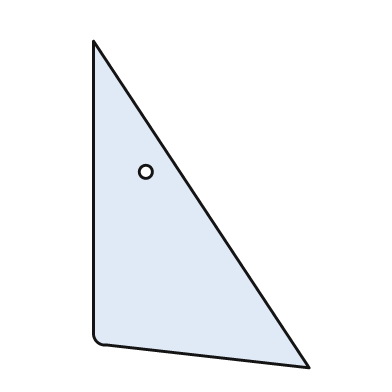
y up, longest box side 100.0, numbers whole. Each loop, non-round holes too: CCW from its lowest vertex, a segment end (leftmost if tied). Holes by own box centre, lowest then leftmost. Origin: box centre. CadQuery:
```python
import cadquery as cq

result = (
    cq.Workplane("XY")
    .moveTo(33.0, -50.0)
    .lineTo(-33.0, 50.0)
    .lineTo(-33.0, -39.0)
    .threePointArc((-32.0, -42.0), (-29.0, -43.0))
    .close()
    .moveTo(-17.0, 10.0)
    .circle(2.0)
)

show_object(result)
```